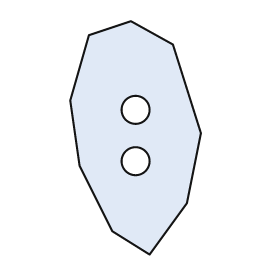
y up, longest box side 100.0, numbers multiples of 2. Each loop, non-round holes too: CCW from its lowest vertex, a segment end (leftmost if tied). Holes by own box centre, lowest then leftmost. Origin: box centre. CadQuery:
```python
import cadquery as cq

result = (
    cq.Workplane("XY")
    .moveTo(6.0, -50.0)
    .lineTo(22.0, -28.0)
    .lineTo(28.0, 2.0)
    .lineTo(16.0, 40.0)
    .lineTo(-2.0, 50.0)
    .lineTo(-20.0, 44.0)
    .lineTo(-28.0, 16.0)
    .lineTo(-24.0, -12.0)
    .lineTo(-10.0, -40.0)
    .close()
    .moveTo(0.0, -10.0)
    .circle(6.0)
    .moveTo(0.0, 12.0)
    .circle(6.0)
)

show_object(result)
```